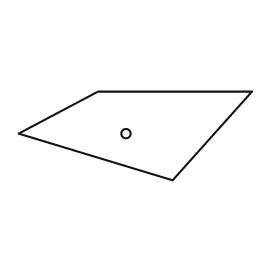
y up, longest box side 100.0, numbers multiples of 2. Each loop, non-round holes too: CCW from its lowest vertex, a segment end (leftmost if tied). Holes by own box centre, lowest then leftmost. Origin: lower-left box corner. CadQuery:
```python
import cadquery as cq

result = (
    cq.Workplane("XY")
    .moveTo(66.0, 0.0)
    .lineTo(100.0, 38.0)
    .lineTo(34.0, 38.0)
    .lineTo(0.0, 20.0)
    .close()
    .moveTo(46.0, 20.0)
    .circle(2.0)
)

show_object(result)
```